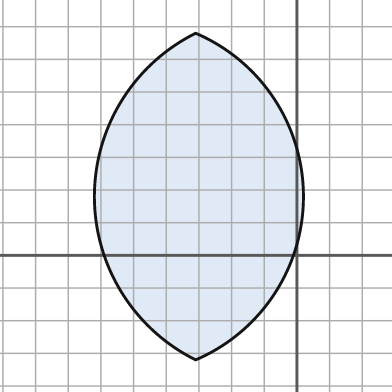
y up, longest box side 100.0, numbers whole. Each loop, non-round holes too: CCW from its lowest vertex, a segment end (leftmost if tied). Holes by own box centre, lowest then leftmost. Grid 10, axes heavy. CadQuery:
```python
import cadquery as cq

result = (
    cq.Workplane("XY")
    .moveTo(-31.0, -32.0)
    .threePointArc((2.0, 18.0), (-31.0, 68.0))
    .threePointArc((-62.0, 18.0), (-31.0, -32.0))
    .close()
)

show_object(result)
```